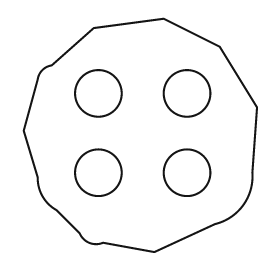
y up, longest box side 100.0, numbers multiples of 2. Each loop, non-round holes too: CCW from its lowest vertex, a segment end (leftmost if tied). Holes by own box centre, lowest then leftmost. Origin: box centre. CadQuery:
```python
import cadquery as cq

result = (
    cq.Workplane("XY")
    .moveTo(6.0, -50.0)
    .lineTo(32.0, -38.0)
    .threePointArc((44.0, -30.0), (48.0, -16.0))
    .lineTo(50.0, 12.0)
    .lineTo(34.0, 38.0)
    .lineTo(10.0, 50.0)
    .lineTo(-20.0, 46.0)
    .lineTo(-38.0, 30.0)
    .threePointArc((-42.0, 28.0), (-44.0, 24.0))
    .lineTo(-50.0, 2.0)
    .lineTo(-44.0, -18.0)
    .threePointArc((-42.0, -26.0), (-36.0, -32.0))
    .lineTo(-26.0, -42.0)
    .threePointArc((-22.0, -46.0), (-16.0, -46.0))
    .close()
    .moveTo(-18.0, -16.0)
    .circle(10.0)
    .moveTo(20.0, -16.0)
    .circle(10.0)
    .moveTo(-18.0, 18.0)
    .circle(10.0)
    .moveTo(20.0, 18.0)
    .circle(10.0)
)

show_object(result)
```